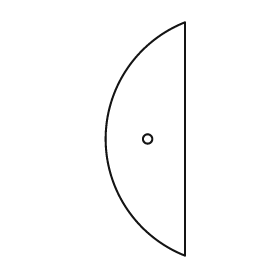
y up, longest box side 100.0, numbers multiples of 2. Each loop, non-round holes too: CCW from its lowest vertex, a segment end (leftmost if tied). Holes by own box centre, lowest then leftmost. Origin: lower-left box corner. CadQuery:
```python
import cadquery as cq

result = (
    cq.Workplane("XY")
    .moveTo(34.0, 0.0)
    .lineTo(34.0, 100.0)
    .threePointArc((0.0, 50.0), (34.0, 0.0))
    .close()
    .moveTo(18.0, 50.0)
    .circle(2.0)
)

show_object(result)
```